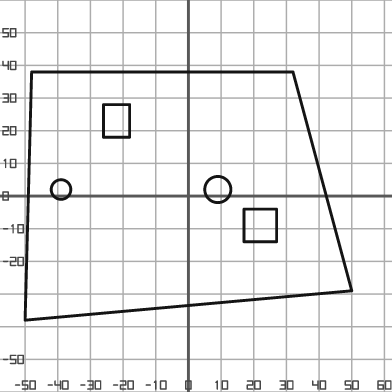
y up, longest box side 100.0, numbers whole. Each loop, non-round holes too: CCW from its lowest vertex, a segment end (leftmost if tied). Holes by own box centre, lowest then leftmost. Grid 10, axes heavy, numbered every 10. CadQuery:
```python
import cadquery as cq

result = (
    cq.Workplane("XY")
    .moveTo(-50.0, -38.0)
    .lineTo(50.0, -29.0)
    .lineTo(32.0, 38.0)
    .lineTo(-48.0, 38.0)
    .close()
    .moveTo(17.0, -14.0)
    .lineTo(27.0, -14.0)
    .lineTo(27.0, -4.0)
    .lineTo(17.0, -4.0)
    .close()
    .moveTo(-39.0, 2.0)
    .circle(3.0)
    .moveTo(9.0, 2.0)
    .circle(4.0)
    .moveTo(-26.0, 18.0)
    .lineTo(-18.0, 18.0)
    .lineTo(-18.0, 28.0)
    .lineTo(-26.0, 28.0)
    .close()
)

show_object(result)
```